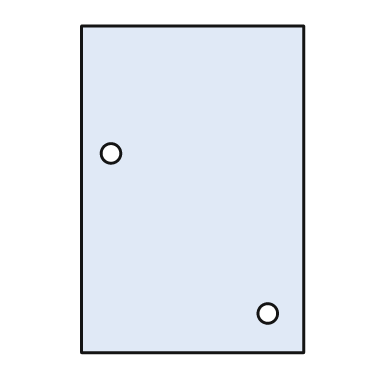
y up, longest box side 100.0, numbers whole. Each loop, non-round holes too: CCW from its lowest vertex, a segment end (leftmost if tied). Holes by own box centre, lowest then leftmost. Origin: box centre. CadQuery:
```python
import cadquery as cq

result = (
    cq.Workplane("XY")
    .moveTo(-34.0, -50.0)
    .lineTo(34.0, -50.0)
    .lineTo(34.0, 50.0)
    .lineTo(-34.0, 50.0)
    .close()
    .moveTo(23.0, -38.0)
    .circle(3.0)
    .moveTo(-25.0, 11.0)
    .circle(3.0)
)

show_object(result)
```